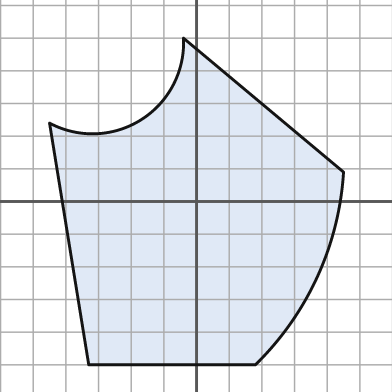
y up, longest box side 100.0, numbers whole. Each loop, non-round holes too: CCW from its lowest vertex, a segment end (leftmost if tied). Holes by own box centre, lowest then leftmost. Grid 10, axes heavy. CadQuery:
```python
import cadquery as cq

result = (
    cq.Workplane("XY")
    .moveTo(-33.0, -50.0)
    .lineTo(18.0, -50.0)
    .threePointArc((37.0, -23.0), (45.0, 9.0))
    .lineTo(-4.0, 50.0)
    .threePointArc((-17.0, 25.0), (-45.0, 24.0))
    .close()
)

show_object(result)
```